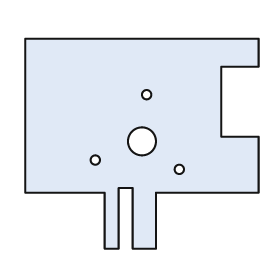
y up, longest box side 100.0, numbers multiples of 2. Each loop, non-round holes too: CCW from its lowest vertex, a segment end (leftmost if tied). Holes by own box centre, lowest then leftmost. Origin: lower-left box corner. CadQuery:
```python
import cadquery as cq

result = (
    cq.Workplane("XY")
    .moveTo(34.0, 0.0)
    .lineTo(40.0, 0.0)
    .lineTo(40.0, 26.0)
    .lineTo(46.0, 26.0)
    .lineTo(46.0, 0.0)
    .lineTo(56.0, 0.0)
    .lineTo(56.0, 24.0)
    .lineTo(100.0, 24.0)
    .lineTo(100.0, 48.0)
    .lineTo(84.0, 48.0)
    .lineTo(84.0, 78.0)
    .lineTo(100.0, 78.0)
    .lineTo(100.0, 90.0)
    .lineTo(0.0, 90.0)
    .lineTo(0.0, 24.0)
    .lineTo(34.0, 24.0)
    .close()
    .moveTo(66.0, 34.0)
    .circle(2.0)
    .moveTo(30.0, 38.0)
    .circle(2.0)
    .moveTo(50.0, 46.0)
    .circle(6.0)
    .moveTo(52.0, 66.0)
    .circle(2.0)
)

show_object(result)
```